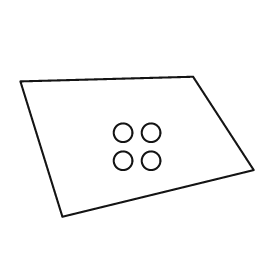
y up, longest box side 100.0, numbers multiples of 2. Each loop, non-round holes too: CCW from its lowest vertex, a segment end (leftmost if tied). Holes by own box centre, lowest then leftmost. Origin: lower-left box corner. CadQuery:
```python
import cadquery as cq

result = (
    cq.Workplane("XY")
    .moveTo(18.0, 0.0)
    .lineTo(100.0, 20.0)
    .lineTo(74.0, 60.0)
    .lineTo(0.0, 58.0)
    .close()
    .moveTo(44.0, 24.0)
    .circle(4.0)
    .moveTo(56.0, 24.0)
    .circle(4.0)
    .moveTo(44.0, 36.0)
    .circle(4.0)
    .moveTo(56.0, 36.0)
    .circle(4.0)
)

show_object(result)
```